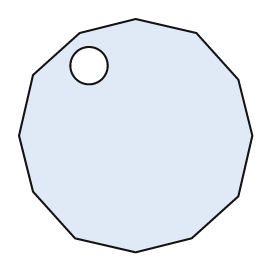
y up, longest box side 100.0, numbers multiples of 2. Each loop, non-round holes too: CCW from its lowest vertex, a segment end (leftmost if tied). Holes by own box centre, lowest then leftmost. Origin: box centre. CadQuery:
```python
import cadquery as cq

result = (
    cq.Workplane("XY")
    .moveTo(0.0, -50.0)
    .lineTo(24.0, -44.0)
    .lineTo(44.0, -26.0)
    .lineTo(50.0, 0.0)
    .lineTo(44.0, 24.0)
    .lineTo(26.0, 44.0)
    .lineTo(0.0, 50.0)
    .lineTo(-24.0, 44.0)
    .lineTo(-44.0, 26.0)
    .lineTo(-50.0, 0.0)
    .lineTo(-44.0, -24.0)
    .lineTo(-26.0, -44.0)
    .close()
    .moveTo(-20.0, 30.0)
    .circle(8.0)
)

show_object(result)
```